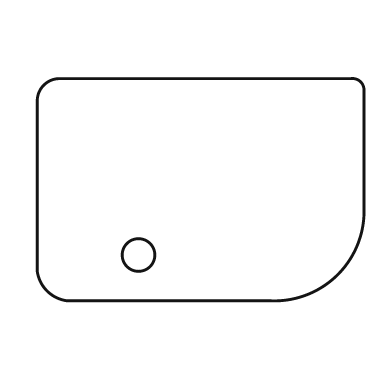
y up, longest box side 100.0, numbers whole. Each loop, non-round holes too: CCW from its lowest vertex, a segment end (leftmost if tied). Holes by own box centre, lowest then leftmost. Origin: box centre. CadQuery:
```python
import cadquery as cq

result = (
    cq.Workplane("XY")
    .moveTo(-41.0, -34.0)
    .lineTo(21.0, -34.0)
    .threePointArc((42.0, -26.0), (50.0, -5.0))
    .lineTo(50.0, 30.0)
    .threePointArc((49.0, 33.0), (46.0, 34.0))
    .lineTo(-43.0, 34.0)
    .threePointArc((-48.0, 32.0), (-50.0, 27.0))
    .lineTo(-50.0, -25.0)
    .threePointArc((-47.0, -31.0), (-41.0, -34.0))
    .close()
    .moveTo(-19.0, -20.0)
    .circle(5.0)
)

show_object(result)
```